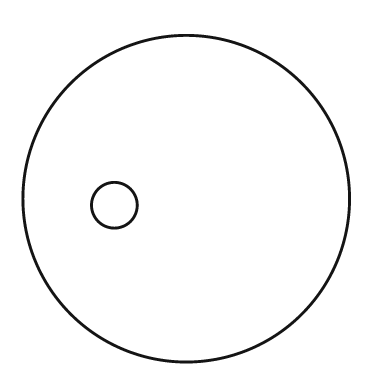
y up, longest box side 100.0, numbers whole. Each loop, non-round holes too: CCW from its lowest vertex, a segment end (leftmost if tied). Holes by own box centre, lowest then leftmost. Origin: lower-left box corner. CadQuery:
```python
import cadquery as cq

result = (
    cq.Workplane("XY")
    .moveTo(50.0, 50.0)
    .circle(50.0)
    .moveTo(28.0, 48.0)
    .circle(7.0)
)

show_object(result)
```